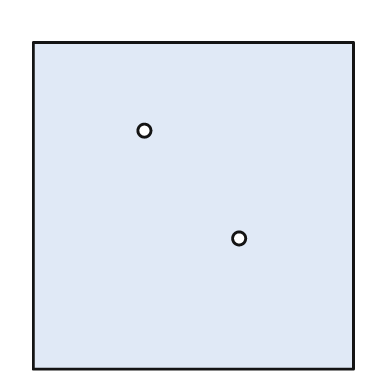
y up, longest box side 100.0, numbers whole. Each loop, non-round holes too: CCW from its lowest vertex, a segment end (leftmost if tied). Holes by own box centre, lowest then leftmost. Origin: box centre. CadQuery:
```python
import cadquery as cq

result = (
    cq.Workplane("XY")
    .moveTo(-49.0, -50.0)
    .lineTo(49.0, -50.0)
    .lineTo(49.0, 50.0)
    .lineTo(-49.0, 50.0)
    .close()
    .moveTo(14.0, -10.0)
    .circle(2.0)
    .moveTo(-15.0, 23.0)
    .circle(2.0)
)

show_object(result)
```